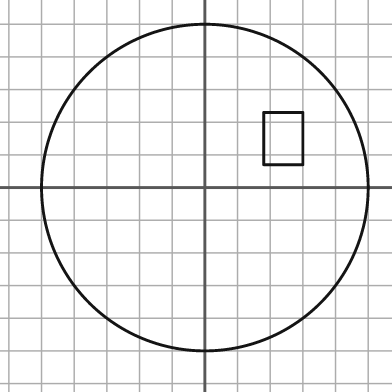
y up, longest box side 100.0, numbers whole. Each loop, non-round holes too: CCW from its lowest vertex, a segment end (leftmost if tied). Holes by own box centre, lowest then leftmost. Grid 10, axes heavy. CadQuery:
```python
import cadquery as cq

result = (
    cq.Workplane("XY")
    .moveTo(0.0, 0.0)
    .circle(50.0)
    .moveTo(18.0, 7.0)
    .lineTo(30.0, 7.0)
    .lineTo(30.0, 23.0)
    .lineTo(18.0, 23.0)
    .close()
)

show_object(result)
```